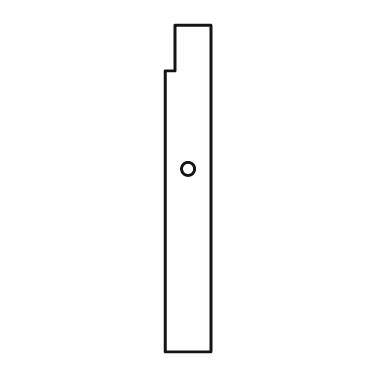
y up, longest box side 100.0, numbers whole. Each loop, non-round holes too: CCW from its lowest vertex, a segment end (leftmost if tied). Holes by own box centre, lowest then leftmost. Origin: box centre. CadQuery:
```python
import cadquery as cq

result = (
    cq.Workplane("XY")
    .moveTo(-7.0, -50.0)
    .lineTo(7.0, -50.0)
    .lineTo(7.0, 50.0)
    .lineTo(-4.0, 50.0)
    .lineTo(-4.0, 36.0)
    .lineTo(-7.0, 36.0)
    .close()
    .moveTo(0.0, 6.0)
    .circle(2.0)
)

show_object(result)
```